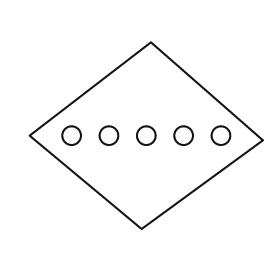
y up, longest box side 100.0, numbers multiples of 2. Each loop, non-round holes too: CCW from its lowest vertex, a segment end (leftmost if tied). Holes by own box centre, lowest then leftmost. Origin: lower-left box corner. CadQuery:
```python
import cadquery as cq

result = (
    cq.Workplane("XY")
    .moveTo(48.0, 0.0)
    .lineTo(100.0, 38.0)
    .lineTo(52.0, 80.0)
    .lineTo(0.0, 40.0)
    .close()
    .moveTo(18.0, 40.0)
    .circle(4.0)
    .moveTo(34.0, 40.0)
    .circle(4.0)
    .moveTo(50.0, 40.0)
    .circle(4.0)
    .moveTo(66.0, 40.0)
    .circle(4.0)
    .moveTo(82.0, 40.0)
    .circle(4.0)
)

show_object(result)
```